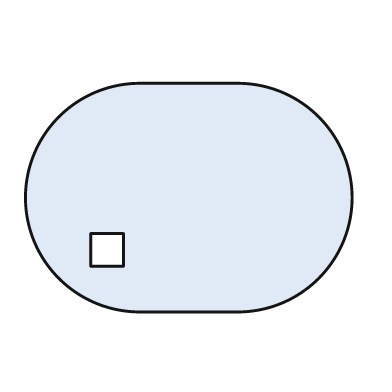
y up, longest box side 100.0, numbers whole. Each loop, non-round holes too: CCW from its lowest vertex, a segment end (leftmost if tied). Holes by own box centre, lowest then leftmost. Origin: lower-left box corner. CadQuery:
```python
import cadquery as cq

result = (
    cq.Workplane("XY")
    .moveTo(35.0, 0.0)
    .lineTo(65.0, 0.0)
    .threePointArc((100.0, 35.0), (65.0, 70.0))
    .lineTo(35.0, 70.0)
    .threePointArc((0.0, 35.0), (35.0, 0.0))
    .close()
    .moveTo(20.0, 14.0)
    .lineTo(30.0, 14.0)
    .lineTo(30.0, 24.0)
    .lineTo(20.0, 24.0)
    .close()
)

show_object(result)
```